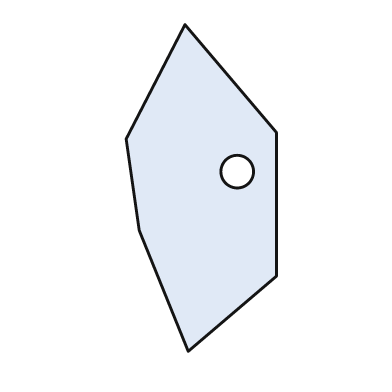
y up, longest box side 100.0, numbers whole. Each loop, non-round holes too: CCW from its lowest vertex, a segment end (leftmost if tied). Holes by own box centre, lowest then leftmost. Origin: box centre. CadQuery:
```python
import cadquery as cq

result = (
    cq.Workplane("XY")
    .moveTo(-4.0, -50.0)
    .lineTo(23.0, -27.0)
    .lineTo(23.0, 17.0)
    .lineTo(-5.0, 50.0)
    .lineTo(-23.0, 15.0)
    .lineTo(-19.0, -13.0)
    .close()
    .moveTo(11.0, 5.0)
    .circle(5.0)
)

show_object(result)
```